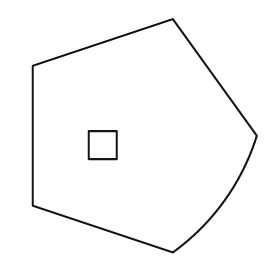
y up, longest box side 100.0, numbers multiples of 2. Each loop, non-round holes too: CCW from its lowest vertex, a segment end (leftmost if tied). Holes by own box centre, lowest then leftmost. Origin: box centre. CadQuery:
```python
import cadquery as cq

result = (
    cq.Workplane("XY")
    .moveTo(12.0, -50.0)
    .threePointArc((34.0, -28.0), (48.0, 0.0))
    .lineTo(12.0, 50.0)
    .lineTo(-48.0, 30.0)
    .lineTo(-48.0, -30.0)
    .close()
    .moveTo(-24.0, -10.0)
    .lineTo(-12.0, -10.0)
    .lineTo(-12.0, 2.0)
    .lineTo(-24.0, 2.0)
    .close()
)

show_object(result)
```